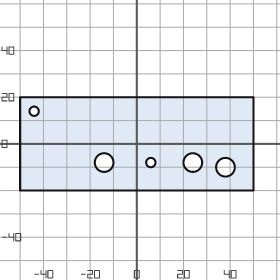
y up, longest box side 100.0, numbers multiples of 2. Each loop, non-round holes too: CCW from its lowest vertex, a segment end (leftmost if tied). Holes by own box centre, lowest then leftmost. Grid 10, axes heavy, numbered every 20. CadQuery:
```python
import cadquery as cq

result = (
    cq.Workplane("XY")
    .moveTo(-50.0, -20.0)
    .lineTo(50.0, -20.0)
    .lineTo(50.0, 20.0)
    .lineTo(-50.0, 20.0)
    .close()
    .moveTo(38.0, -10.0)
    .circle(4.0)
    .moveTo(-14.0, -8.0)
    .circle(4.0)
    .moveTo(6.0, -8.0)
    .circle(2.0)
    .moveTo(24.0, -8.0)
    .circle(4.0)
    .moveTo(-44.0, 14.0)
    .circle(2.0)
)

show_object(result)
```